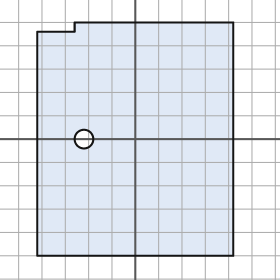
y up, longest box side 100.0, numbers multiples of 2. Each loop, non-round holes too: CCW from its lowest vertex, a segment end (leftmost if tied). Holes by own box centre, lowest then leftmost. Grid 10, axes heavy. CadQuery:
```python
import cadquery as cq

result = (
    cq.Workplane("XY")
    .moveTo(-42.0, -50.0)
    .lineTo(42.0, -50.0)
    .lineTo(42.0, 50.0)
    .lineTo(-26.0, 50.0)
    .lineTo(-26.0, 46.0)
    .lineTo(-42.0, 46.0)
    .close()
    .moveTo(-22.0, 0.0)
    .circle(4.0)
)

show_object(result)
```